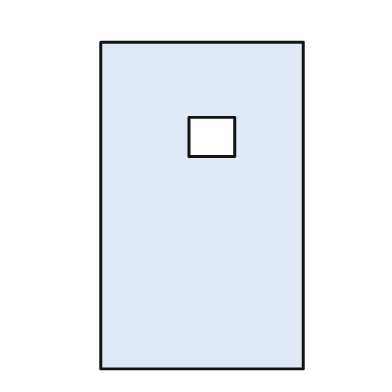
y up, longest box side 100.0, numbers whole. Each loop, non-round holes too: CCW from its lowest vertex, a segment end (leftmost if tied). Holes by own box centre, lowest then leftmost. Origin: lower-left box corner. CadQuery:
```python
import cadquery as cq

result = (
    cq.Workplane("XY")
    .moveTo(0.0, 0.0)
    .lineTo(62.0, 0.0)
    .lineTo(62.0, 100.0)
    .lineTo(0.0, 100.0)
    .close()
    .moveTo(27.0, 65.0)
    .lineTo(41.0, 65.0)
    .lineTo(41.0, 77.0)
    .lineTo(27.0, 77.0)
    .close()
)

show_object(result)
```